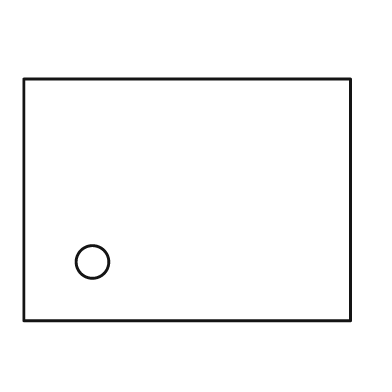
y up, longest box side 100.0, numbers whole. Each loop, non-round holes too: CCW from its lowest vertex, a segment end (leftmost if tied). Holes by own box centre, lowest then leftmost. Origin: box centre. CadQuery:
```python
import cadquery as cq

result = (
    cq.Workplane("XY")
    .moveTo(-50.0, -37.0)
    .lineTo(50.0, -37.0)
    .lineTo(50.0, 37.0)
    .lineTo(-50.0, 37.0)
    .close()
    .moveTo(-29.0, -19.0)
    .circle(5.0)
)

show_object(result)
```